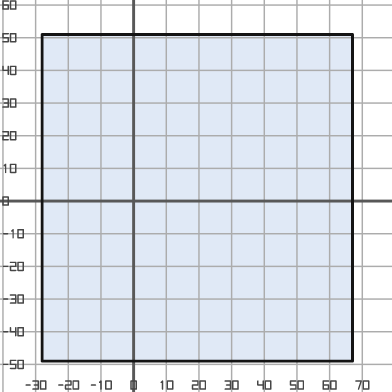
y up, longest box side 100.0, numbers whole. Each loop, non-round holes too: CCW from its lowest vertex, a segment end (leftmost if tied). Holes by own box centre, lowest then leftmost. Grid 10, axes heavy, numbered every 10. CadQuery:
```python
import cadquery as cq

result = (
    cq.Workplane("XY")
    .moveTo(-28.0, -49.0)
    .lineTo(67.0, -49.0)
    .lineTo(67.0, 51.0)
    .lineTo(-28.0, 51.0)
    .close()
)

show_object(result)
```